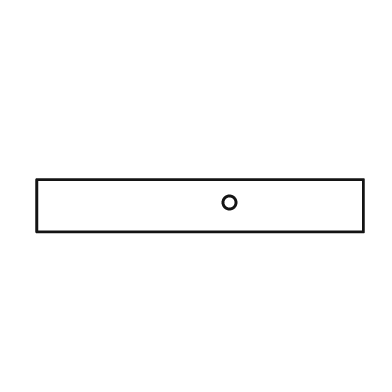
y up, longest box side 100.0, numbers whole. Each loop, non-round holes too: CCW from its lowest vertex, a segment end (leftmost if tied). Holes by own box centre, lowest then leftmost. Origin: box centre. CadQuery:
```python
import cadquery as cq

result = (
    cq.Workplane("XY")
    .moveTo(-50.0, -8.0)
    .lineTo(50.0, -8.0)
    .lineTo(50.0, 8.0)
    .lineTo(-50.0, 8.0)
    .close()
    .moveTo(9.0, 1.0)
    .circle(2.0)
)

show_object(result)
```